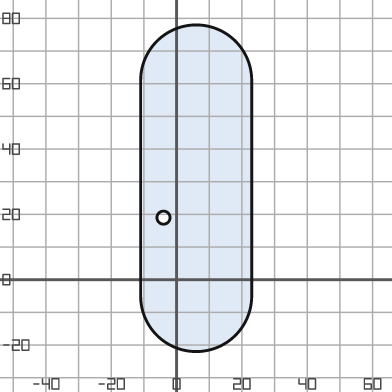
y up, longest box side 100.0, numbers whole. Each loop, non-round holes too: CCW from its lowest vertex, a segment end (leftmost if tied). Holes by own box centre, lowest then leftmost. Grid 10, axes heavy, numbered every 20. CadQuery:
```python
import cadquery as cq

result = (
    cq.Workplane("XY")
    .moveTo(-11.0, -5.0)
    .threePointArc((6.0, -22.0), (23.0, -5.0))
    .lineTo(23.0, 61.0)
    .threePointArc((6.0, 78.0), (-11.0, 61.0))
    .close()
    .moveTo(-4.0, 19.0)
    .circle(2.0)
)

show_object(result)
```